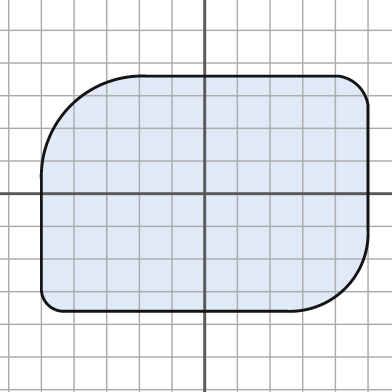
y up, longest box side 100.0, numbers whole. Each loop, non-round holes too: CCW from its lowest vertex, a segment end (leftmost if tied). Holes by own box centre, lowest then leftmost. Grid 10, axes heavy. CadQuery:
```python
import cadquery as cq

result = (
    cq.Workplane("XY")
    .moveTo(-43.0, -36.0)
    .lineTo(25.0, -36.0)
    .threePointArc((43.0, -29.0), (50.0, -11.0))
    .lineTo(50.0, 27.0)
    .threePointArc((47.0, 33.0), (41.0, 36.0))
    .lineTo(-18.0, 36.0)
    .threePointArc((-41.0, 27.0), (-50.0, 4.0))
    .lineTo(-50.0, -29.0)
    .threePointArc((-48.0, -34.0), (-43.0, -36.0))
    .close()
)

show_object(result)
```